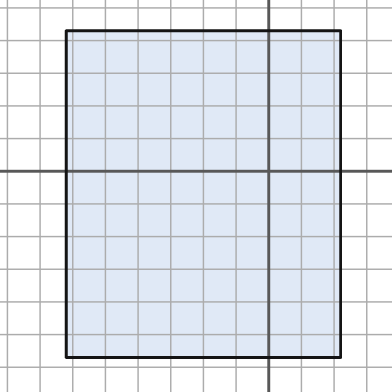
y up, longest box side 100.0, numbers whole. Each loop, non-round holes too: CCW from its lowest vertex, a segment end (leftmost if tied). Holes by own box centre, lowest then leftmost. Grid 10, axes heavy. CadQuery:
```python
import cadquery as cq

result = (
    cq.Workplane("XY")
    .moveTo(-62.0, -57.0)
    .lineTo(22.0, -57.0)
    .lineTo(22.0, 43.0)
    .lineTo(-62.0, 43.0)
    .close()
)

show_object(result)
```